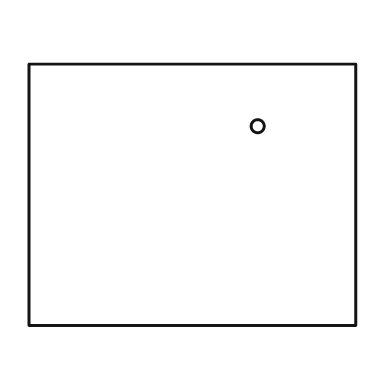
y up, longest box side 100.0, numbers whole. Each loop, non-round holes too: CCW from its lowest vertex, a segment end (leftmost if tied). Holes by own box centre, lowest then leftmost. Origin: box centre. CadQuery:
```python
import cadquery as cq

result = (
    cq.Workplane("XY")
    .moveTo(-50.0, -40.0)
    .lineTo(50.0, -40.0)
    .lineTo(50.0, 40.0)
    .lineTo(-50.0, 40.0)
    .close()
    .moveTo(20.0, 21.0)
    .circle(2.0)
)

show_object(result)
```